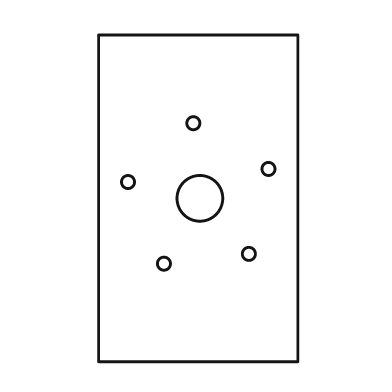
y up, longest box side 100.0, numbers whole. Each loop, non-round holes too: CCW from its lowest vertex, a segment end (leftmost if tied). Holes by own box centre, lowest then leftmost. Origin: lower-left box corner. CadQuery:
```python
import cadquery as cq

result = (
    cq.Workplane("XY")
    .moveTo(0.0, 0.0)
    .lineTo(61.0, 0.0)
    .lineTo(61.0, 100.0)
    .lineTo(0.0, 100.0)
    .close()
    .moveTo(20.0, 30.0)
    .circle(2.0)
    .moveTo(46.0, 33.0)
    .circle(2.0)
    .moveTo(31.0, 50.0)
    .circle(7.0)
    .moveTo(9.0, 55.0)
    .circle(2.0)
    .moveTo(52.0, 59.0)
    .circle(2.0)
    .moveTo(29.0, 73.0)
    .circle(2.0)
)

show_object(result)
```